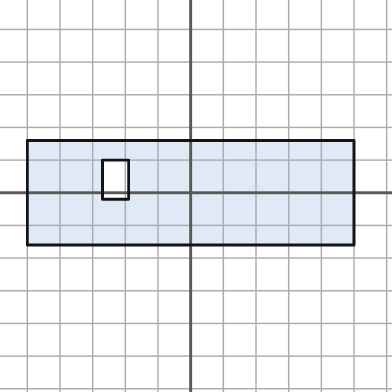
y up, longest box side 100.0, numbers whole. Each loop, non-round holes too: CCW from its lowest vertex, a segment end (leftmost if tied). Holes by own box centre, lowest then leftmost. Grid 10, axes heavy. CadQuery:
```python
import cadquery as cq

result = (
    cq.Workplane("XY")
    .moveTo(-50.0, -16.0)
    .lineTo(50.0, -16.0)
    .lineTo(50.0, 16.0)
    .lineTo(-50.0, 16.0)
    .close()
    .moveTo(-27.0, -2.0)
    .lineTo(-19.0, -2.0)
    .lineTo(-19.0, 10.0)
    .lineTo(-27.0, 10.0)
    .close()
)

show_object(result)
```